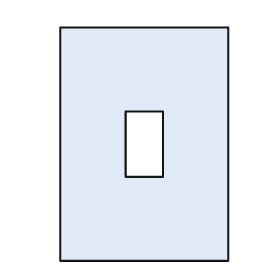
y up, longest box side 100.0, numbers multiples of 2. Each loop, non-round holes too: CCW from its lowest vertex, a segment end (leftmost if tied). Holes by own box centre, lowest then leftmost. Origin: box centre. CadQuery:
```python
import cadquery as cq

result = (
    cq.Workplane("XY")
    .moveTo(-36.0, -50.0)
    .lineTo(36.0, -50.0)
    .lineTo(36.0, 50.0)
    .lineTo(-36.0, 50.0)
    .close()
    .moveTo(-8.0, -14.0)
    .lineTo(8.0, -14.0)
    .lineTo(8.0, 14.0)
    .lineTo(-8.0, 14.0)
    .close()
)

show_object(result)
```